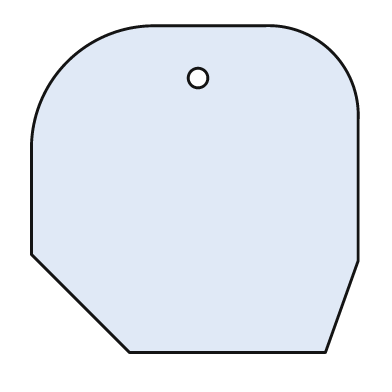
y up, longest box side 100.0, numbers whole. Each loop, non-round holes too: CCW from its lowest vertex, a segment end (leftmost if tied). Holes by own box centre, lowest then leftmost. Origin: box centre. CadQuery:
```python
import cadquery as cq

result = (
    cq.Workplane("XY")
    .moveTo(-20.0, -50.0)
    .lineTo(40.0, -50.0)
    .lineTo(50.0, -22.0)
    .lineTo(50.0, 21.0)
    .threePointArc((42.0, 42.0), (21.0, 50.0))
    .lineTo(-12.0, 50.0)
    .threePointArc((-39.0, 39.0), (-50.0, 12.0))
    .lineTo(-50.0, -20.0)
    .close()
    .moveTo(1.0, 34.0)
    .circle(3.0)
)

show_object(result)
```